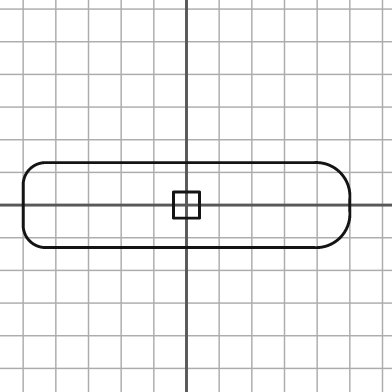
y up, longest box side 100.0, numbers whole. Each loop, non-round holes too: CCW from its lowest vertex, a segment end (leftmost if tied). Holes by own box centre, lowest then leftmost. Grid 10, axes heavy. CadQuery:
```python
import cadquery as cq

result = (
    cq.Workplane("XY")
    .moveTo(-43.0, -13.0)
    .lineTo(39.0, -13.0)
    .threePointArc((47.0, -10.0), (50.0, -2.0))
    .lineTo(50.0, 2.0)
    .threePointArc((47.0, 10.0), (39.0, 13.0))
    .lineTo(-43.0, 13.0)
    .threePointArc((-48.0, 11.0), (-50.0, 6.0))
    .lineTo(-50.0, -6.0)
    .threePointArc((-48.0, -11.0), (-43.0, -13.0))
    .close()
    .moveTo(-4.0, -4.0)
    .lineTo(4.0, -4.0)
    .lineTo(4.0, 4.0)
    .lineTo(-4.0, 4.0)
    .close()
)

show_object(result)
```